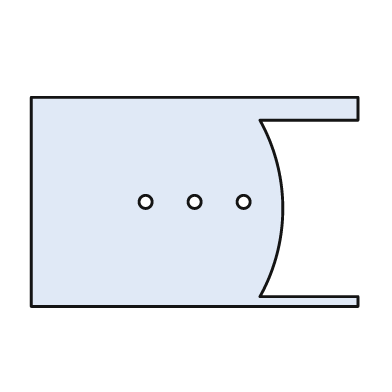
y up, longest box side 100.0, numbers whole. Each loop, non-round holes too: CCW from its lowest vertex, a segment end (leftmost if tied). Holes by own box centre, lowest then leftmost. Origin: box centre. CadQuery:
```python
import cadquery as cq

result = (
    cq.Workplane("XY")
    .moveTo(-50.0, -32.0)
    .lineTo(50.0, -32.0)
    .lineTo(50.0, -29.0)
    .lineTo(20.0, -29.0)
    .threePointArc((27.0, -2.0), (20.0, 25.0))
    .lineTo(50.0, 25.0)
    .lineTo(50.0, 32.0)
    .lineTo(-50.0, 32.0)
    .close()
    .moveTo(-15.0, 0.0)
    .circle(2.0)
    .moveTo(0.0, 0.0)
    .circle(2.0)
    .moveTo(15.0, 0.0)
    .circle(2.0)
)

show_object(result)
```